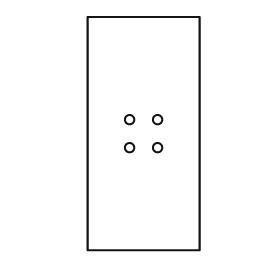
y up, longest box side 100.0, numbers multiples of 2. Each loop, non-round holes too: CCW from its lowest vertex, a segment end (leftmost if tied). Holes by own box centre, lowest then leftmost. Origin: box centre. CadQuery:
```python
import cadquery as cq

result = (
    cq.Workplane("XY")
    .moveTo(-24.0, -50.0)
    .lineTo(24.0, -50.0)
    .lineTo(24.0, 50.0)
    .lineTo(-24.0, 50.0)
    .close()
    .moveTo(-6.0, -6.0)
    .circle(2.0)
    .moveTo(6.0, -6.0)
    .circle(2.0)
    .moveTo(-6.0, 6.0)
    .circle(2.0)
    .moveTo(6.0, 6.0)
    .circle(2.0)
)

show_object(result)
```